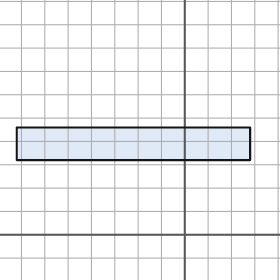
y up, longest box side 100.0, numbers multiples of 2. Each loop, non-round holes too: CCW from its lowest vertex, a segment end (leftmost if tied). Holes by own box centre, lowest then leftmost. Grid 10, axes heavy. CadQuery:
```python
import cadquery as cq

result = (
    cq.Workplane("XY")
    .moveTo(-72.0, 32.0)
    .lineTo(28.0, 32.0)
    .lineTo(28.0, 46.0)
    .lineTo(-72.0, 46.0)
    .close()
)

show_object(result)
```